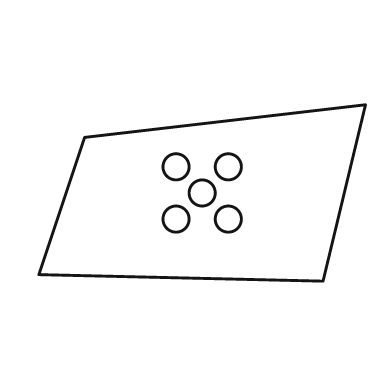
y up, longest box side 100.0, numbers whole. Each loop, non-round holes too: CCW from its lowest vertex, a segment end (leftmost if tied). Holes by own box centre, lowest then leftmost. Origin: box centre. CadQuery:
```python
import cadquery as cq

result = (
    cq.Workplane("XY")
    .moveTo(37.0, -27.0)
    .lineTo(50.0, 27.0)
    .lineTo(-36.0, 17.0)
    .lineTo(-50.0, -25.0)
    .close()
    .moveTo(-8.0, -8.0)
    .circle(4.0)
    .moveTo(8.0, -8.0)
    .circle(4.0)
    .moveTo(0.0, 0.0)
    .circle(4.0)
    .moveTo(-8.0, 8.0)
    .circle(4.0)
    .moveTo(8.0, 8.0)
    .circle(4.0)
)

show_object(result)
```